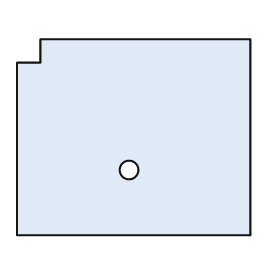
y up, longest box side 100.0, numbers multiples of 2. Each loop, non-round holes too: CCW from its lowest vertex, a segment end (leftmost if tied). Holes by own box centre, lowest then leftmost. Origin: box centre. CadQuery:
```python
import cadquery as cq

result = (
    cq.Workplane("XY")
    .moveTo(-50.0, -42.0)
    .lineTo(50.0, -42.0)
    .lineTo(50.0, 42.0)
    .lineTo(-40.0, 42.0)
    .lineTo(-40.0, 32.0)
    .lineTo(-50.0, 32.0)
    .close()
    .moveTo(-2.0, -14.0)
    .circle(4.0)
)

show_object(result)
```